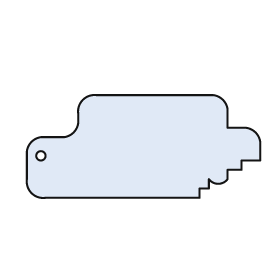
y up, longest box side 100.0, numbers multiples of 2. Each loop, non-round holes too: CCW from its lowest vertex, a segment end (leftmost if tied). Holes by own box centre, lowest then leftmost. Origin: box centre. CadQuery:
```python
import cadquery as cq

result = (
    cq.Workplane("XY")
    .moveTo(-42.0, -22.0)
    .lineTo(24.0, -22.0)
    .lineTo(24.0, -18.0)
    .lineTo(28.0, -18.0)
    .lineTo(28.0, -14.0)
    .threePointArc((32.0, -16.0), (36.0, -14.0))
    .lineTo(36.0, -10.0)
    .lineTo(42.0, -10.0)
    .lineTo(42.0, -6.0)
    .lineTo(50.0, -6.0)
    .lineTo(50.0, 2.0)
    .threePointArc((48.0, 6.0), (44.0, 8.0))
    .lineTo(36.0, 8.0)
    .lineTo(36.0, 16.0)
    .threePointArc((34.0, 20.0), (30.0, 22.0))
    .lineTo(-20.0, 22.0)
    .threePointArc((-26.0, 20.0), (-28.0, 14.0))
    .lineTo(-28.0, 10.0)
    .threePointArc((-30.0, 6.0), (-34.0, 4.0))
    .lineTo(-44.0, 4.0)
    .threePointArc((-48.0, 2.0), (-50.0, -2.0))
    .lineTo(-50.0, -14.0)
    .threePointArc((-48.0, -20.0), (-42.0, -22.0))
    .close()
    .moveTo(-44.0, -4.0)
    .circle(2.0)
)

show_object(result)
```